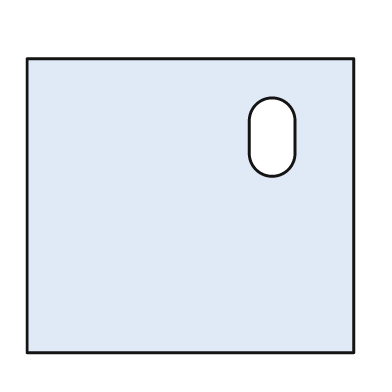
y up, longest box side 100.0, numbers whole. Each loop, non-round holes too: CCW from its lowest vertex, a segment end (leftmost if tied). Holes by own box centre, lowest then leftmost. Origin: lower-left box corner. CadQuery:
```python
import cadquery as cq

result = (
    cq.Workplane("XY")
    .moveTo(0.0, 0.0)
    .lineTo(100.0, 0.0)
    .lineTo(100.0, 90.0)
    .lineTo(0.0, 90.0)
    .close()
    .moveTo(68.0, 61.0)
    .threePointArc((75.0, 54.0), (82.0, 61.0))
    .lineTo(82.0, 71.0)
    .threePointArc((75.0, 78.0), (68.0, 71.0))
    .close()
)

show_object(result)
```